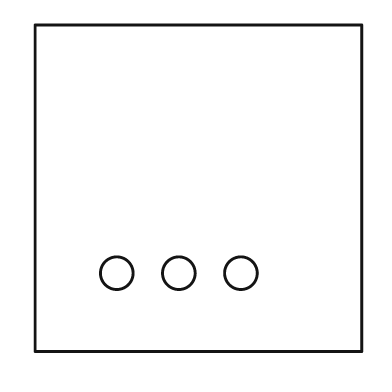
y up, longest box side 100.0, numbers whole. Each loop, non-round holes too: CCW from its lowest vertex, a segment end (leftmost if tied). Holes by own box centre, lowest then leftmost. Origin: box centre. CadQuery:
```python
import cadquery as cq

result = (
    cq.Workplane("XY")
    .moveTo(-50.0, -50.0)
    .lineTo(50.0, -50.0)
    .lineTo(50.0, 50.0)
    .lineTo(-50.0, 50.0)
    .close()
    .moveTo(-25.0, -26.0)
    .circle(5.0)
    .moveTo(-6.0, -26.0)
    .circle(5.0)
    .moveTo(13.0, -26.0)
    .circle(5.0)
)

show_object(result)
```